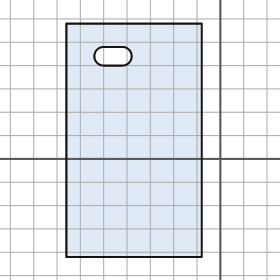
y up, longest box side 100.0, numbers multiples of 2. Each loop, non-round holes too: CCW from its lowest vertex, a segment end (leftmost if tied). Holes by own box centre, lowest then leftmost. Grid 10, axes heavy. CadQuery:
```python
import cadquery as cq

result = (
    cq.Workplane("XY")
    .moveTo(-66.0, -42.0)
    .lineTo(-8.0, -42.0)
    .lineTo(-8.0, 58.0)
    .lineTo(-66.0, 58.0)
    .close()
    .moveTo(-50.0, 40.0)
    .lineTo(-42.0, 40.0)
    .threePointArc((-38.0, 44.0), (-42.0, 48.0))
    .lineTo(-50.0, 48.0)
    .threePointArc((-54.0, 44.0), (-50.0, 40.0))
    .close()
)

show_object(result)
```